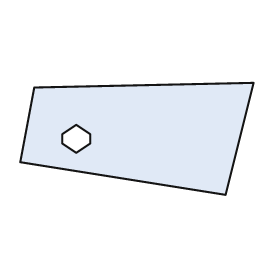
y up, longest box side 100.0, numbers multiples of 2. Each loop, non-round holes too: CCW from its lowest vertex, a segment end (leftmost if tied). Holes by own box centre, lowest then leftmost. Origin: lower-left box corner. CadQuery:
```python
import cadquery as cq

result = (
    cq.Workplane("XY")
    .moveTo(88.0, 0.0)
    .lineTo(100.0, 48.0)
    .lineTo(6.0, 46.0)
    .lineTo(0.0, 14.0)
    .close()
    .moveTo(24.0, 18.0)
    .lineTo(30.0, 22.0)
    .lineTo(30.0, 26.0)
    .lineTo(24.0, 30.0)
    .lineTo(18.0, 26.0)
    .lineTo(18.0, 22.0)
    .close()
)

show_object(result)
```